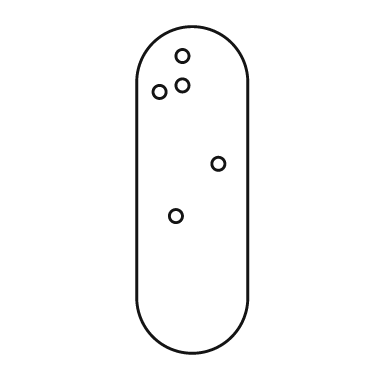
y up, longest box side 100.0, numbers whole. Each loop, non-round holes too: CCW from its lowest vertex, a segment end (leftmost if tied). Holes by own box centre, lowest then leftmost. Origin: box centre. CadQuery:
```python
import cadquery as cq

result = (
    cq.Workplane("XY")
    .moveTo(-17.0, -33.0)
    .threePointArc((0.0, -50.0), (17.0, -33.0))
    .lineTo(17.0, 33.0)
    .threePointArc((0.0, 50.0), (-17.0, 33.0))
    .close()
    .moveTo(-5.0, -8.0)
    .circle(2.0)
    .moveTo(8.0, 8.0)
    .circle(2.0)
    .moveTo(-10.0, 30.0)
    .circle(2.0)
    .moveTo(-3.0, 32.0)
    .circle(2.0)
    .moveTo(-3.0, 41.0)
    .circle(2.0)
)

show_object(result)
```